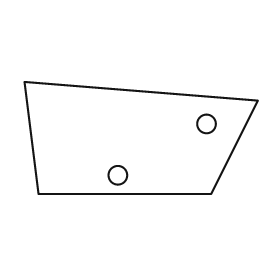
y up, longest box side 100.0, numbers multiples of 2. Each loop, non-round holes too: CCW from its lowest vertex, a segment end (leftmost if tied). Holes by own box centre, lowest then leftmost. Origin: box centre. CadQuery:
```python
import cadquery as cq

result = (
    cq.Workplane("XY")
    .moveTo(-44.0, -24.0)
    .lineTo(30.0, -24.0)
    .lineTo(50.0, 16.0)
    .lineTo(-50.0, 24.0)
    .close()
    .moveTo(-10.0, -16.0)
    .circle(4.0)
    .moveTo(28.0, 6.0)
    .circle(4.0)
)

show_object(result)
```